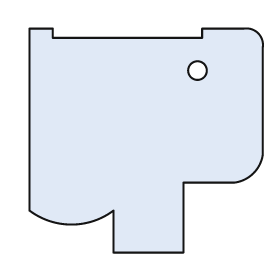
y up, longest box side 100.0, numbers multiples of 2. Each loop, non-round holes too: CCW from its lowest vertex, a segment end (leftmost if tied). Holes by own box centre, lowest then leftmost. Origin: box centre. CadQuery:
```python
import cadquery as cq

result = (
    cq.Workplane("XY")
    .moveTo(-14.0, -48.0)
    .lineTo(16.0, -48.0)
    .lineTo(16.0, -18.0)
    .lineTo(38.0, -18.0)
    .threePointArc((46.0, -14.0), (50.0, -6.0))
    .lineTo(50.0, 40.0)
    .threePointArc((48.0, 46.0), (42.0, 48.0))
    .lineTo(24.0, 48.0)
    .lineTo(24.0, 44.0)
    .lineTo(-40.0, 44.0)
    .lineTo(-40.0, 48.0)
    .lineTo(-50.0, 48.0)
    .lineTo(-50.0, -30.0)
    .threePointArc((-32.0, -36.0), (-14.0, -30.0))
    .close()
    .moveTo(22.0, 30.0)
    .circle(4.0)
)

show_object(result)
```